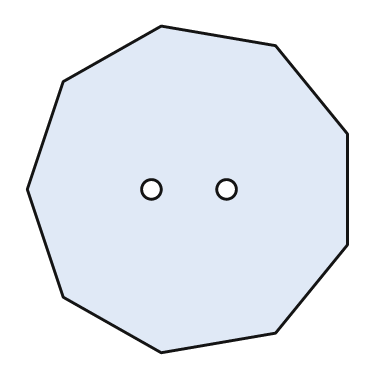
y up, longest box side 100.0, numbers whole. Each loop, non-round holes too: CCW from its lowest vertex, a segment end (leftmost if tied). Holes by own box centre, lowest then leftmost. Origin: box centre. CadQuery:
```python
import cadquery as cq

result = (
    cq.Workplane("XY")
    .moveTo(-8.0, -50.0)
    .lineTo(27.0, -44.0)
    .lineTo(49.0, -17.0)
    .lineTo(49.0, 17.0)
    .lineTo(27.0, 44.0)
    .lineTo(-8.0, 50.0)
    .lineTo(-38.0, 33.0)
    .lineTo(-49.0, 0.0)
    .lineTo(-38.0, -33.0)
    .close()
    .moveTo(-11.0, 0.0)
    .circle(3.0)
    .moveTo(12.0, 0.0)
    .circle(3.0)
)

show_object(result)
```